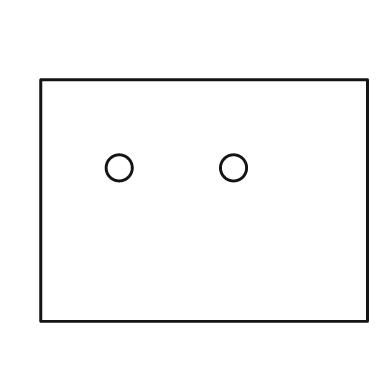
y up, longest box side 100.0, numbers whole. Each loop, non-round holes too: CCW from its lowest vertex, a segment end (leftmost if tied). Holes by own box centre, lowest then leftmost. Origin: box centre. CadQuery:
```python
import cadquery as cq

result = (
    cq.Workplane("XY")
    .moveTo(-50.0, -37.0)
    .lineTo(50.0, -37.0)
    .lineTo(50.0, 37.0)
    .lineTo(-50.0, 37.0)
    .close()
    .moveTo(-26.0, 10.0)
    .circle(4.0)
    .moveTo(9.0, 10.0)
    .circle(4.0)
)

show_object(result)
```